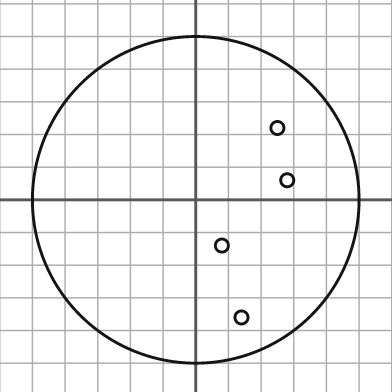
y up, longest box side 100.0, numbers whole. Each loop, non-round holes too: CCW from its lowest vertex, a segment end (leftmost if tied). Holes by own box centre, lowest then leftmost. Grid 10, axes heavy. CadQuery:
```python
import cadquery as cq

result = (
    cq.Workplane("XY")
    .moveTo(0.0, 0.0)
    .circle(50.0)
    .moveTo(14.0, -36.0)
    .circle(2.0)
    .moveTo(8.0, -14.0)
    .circle(2.0)
    .moveTo(28.0, 6.0)
    .circle(2.0)
    .moveTo(25.0, 22.0)
    .circle(2.0)
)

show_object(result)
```